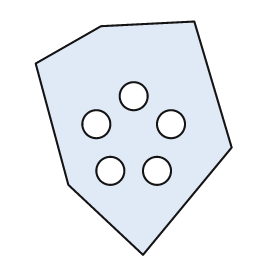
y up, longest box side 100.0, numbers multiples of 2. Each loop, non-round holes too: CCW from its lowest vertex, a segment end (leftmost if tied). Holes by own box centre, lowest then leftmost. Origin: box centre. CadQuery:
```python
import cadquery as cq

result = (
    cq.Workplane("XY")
    .moveTo(4.0, -50.0)
    .lineTo(42.0, -4.0)
    .lineTo(26.0, 50.0)
    .lineTo(-14.0, 48.0)
    .lineTo(-42.0, 32.0)
    .lineTo(-28.0, -20.0)
    .close()
    .moveTo(-10.0, -14.0)
    .circle(6.0)
    .moveTo(10.0, -14.0)
    .circle(6.0)
    .moveTo(-16.0, 6.0)
    .circle(6.0)
    .moveTo(16.0, 6.0)
    .circle(6.0)
    .moveTo(0.0, 18.0)
    .circle(6.0)
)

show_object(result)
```